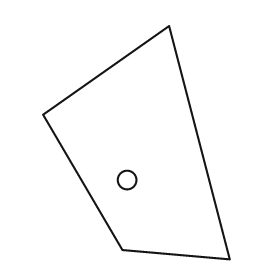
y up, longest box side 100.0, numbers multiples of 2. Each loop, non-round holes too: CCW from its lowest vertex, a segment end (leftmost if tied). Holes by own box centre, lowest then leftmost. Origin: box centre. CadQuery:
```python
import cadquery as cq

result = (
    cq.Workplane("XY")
    .moveTo(40.0, -50.0)
    .lineTo(14.0, 50.0)
    .lineTo(-40.0, 12.0)
    .lineTo(-6.0, -46.0)
    .close()
    .moveTo(-4.0, -16.0)
    .circle(4.0)
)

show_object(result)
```